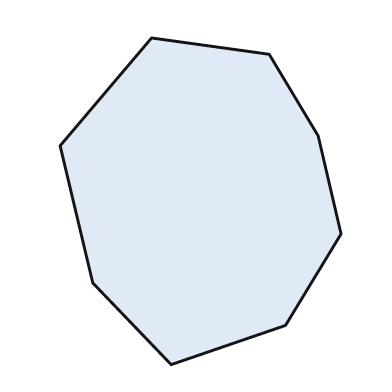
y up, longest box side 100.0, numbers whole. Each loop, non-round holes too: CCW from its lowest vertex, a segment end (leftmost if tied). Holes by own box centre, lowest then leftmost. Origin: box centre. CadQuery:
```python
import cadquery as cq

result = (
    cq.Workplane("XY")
    .moveTo(-9.0, -50.0)
    .lineTo(26.0, -38.0)
    .lineTo(43.0, -10.0)
    .lineTo(36.0, 20.0)
    .lineTo(21.0, 45.0)
    .lineTo(-15.0, 50.0)
    .lineTo(-43.0, 17.0)
    .lineTo(-33.0, -25.0)
    .close()
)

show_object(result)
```